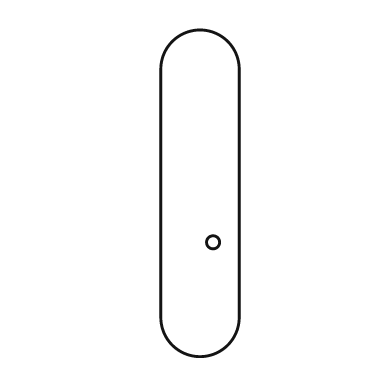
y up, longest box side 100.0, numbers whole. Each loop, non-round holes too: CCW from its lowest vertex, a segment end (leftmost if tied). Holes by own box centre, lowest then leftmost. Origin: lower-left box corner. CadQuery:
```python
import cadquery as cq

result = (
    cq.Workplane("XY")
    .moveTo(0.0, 12.0)
    .threePointArc((12.0, 0.0), (24.0, 12.0))
    .lineTo(24.0, 88.0)
    .threePointArc((12.0, 100.0), (0.0, 88.0))
    .close()
    .moveTo(16.0, 35.0)
    .circle(2.0)
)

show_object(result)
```